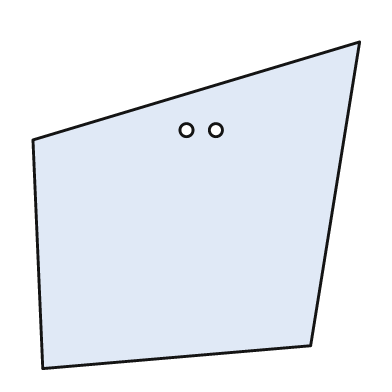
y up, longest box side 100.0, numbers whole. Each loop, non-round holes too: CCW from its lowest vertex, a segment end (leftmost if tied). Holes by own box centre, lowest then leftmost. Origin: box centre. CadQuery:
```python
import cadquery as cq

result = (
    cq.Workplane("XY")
    .moveTo(-47.0, -50.0)
    .lineTo(35.0, -43.0)
    .lineTo(50.0, 50.0)
    .lineTo(-50.0, 20.0)
    .close()
    .moveTo(-3.0, 23.0)
    .circle(2.0)
    .moveTo(6.0, 23.0)
    .circle(2.0)
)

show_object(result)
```